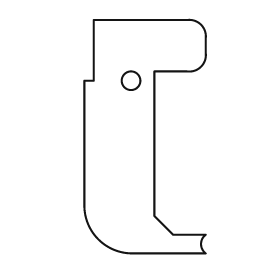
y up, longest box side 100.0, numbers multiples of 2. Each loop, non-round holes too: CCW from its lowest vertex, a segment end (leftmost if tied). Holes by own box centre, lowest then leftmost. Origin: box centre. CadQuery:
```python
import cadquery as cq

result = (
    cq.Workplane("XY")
    .moveTo(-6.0, -50.0)
    .lineTo(26.0, -50.0)
    .threePointArc((24.0, -46.0), (26.0, -42.0))
    .lineTo(12.0, -42.0)
    .lineTo(4.0, -34.0)
    .lineTo(4.0, 28.0)
    .lineTo(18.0, 28.0)
    .threePointArc((24.0, 30.0), (26.0, 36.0))
    .lineTo(26.0, 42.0)
    .threePointArc((24.0, 48.0), (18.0, 50.0))
    .lineTo(-22.0, 50.0)
    .lineTo(-22.0, 24.0)
    .lineTo(-26.0, 24.0)
    .lineTo(-26.0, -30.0)
    .threePointArc((-20.0, -44.0), (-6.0, -50.0))
    .close()
    .moveTo(-6.0, 24.0)
    .circle(4.0)
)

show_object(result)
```